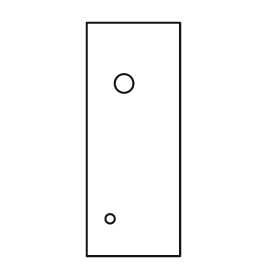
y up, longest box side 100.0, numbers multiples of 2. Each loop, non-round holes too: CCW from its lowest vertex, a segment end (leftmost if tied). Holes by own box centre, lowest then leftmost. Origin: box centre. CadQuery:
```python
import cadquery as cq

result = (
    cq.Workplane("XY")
    .moveTo(-20.0, -50.0)
    .lineTo(20.0, -50.0)
    .lineTo(20.0, 50.0)
    .lineTo(-20.0, 50.0)
    .close()
    .moveTo(-10.0, -34.0)
    .circle(2.0)
    .moveTo(-4.0, 24.0)
    .circle(4.0)
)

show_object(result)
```